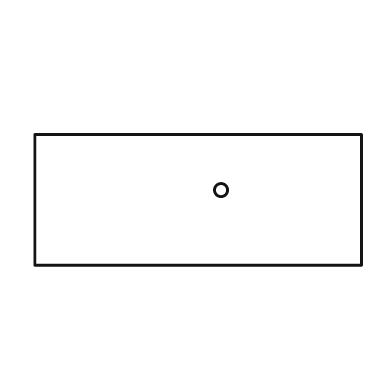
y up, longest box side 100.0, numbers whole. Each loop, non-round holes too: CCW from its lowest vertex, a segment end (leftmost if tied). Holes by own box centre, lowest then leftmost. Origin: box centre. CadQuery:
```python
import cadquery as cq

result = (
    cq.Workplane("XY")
    .moveTo(-50.0, -20.0)
    .lineTo(50.0, -20.0)
    .lineTo(50.0, 20.0)
    .lineTo(-50.0, 20.0)
    .close()
    .moveTo(7.0, 3.0)
    .circle(2.0)
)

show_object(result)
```